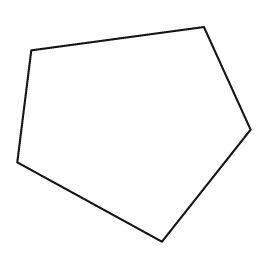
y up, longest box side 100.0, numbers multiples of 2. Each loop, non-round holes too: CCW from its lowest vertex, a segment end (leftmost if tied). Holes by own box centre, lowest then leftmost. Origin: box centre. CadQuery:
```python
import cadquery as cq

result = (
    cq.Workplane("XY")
    .moveTo(12.0, -46.0)
    .lineTo(50.0, 2.0)
    .lineTo(30.0, 46.0)
    .lineTo(-44.0, 36.0)
    .lineTo(-50.0, -12.0)
    .close()
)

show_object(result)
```